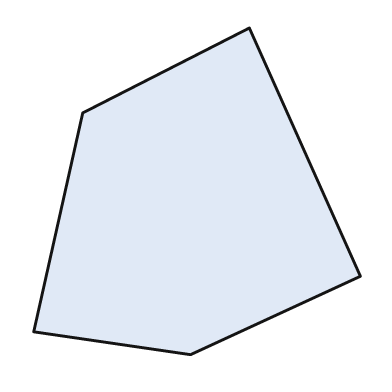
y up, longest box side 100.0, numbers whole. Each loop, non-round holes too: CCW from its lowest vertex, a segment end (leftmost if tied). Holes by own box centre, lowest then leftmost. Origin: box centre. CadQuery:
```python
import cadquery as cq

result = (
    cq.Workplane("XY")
    .moveTo(-2.0, -50.0)
    .lineTo(50.0, -26.0)
    .lineTo(16.0, 50.0)
    .lineTo(-35.0, 24.0)
    .lineTo(-50.0, -43.0)
    .close()
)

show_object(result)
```